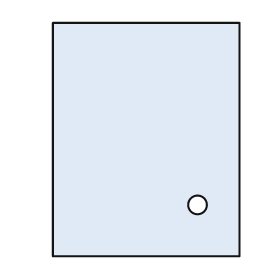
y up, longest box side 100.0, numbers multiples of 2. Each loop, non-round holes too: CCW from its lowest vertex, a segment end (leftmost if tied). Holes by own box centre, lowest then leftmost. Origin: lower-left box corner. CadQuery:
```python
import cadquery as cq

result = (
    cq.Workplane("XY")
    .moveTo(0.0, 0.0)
    .lineTo(80.0, 0.0)
    .lineTo(80.0, 100.0)
    .lineTo(0.0, 100.0)
    .close()
    .moveTo(62.0, 22.0)
    .circle(4.0)
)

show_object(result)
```